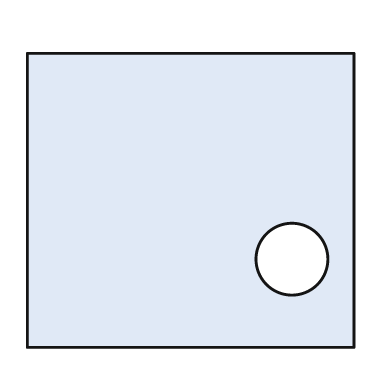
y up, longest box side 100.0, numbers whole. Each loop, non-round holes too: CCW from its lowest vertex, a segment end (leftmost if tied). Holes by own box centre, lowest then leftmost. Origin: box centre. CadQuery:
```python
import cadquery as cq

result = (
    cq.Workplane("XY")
    .moveTo(-50.0, -45.0)
    .lineTo(50.0, -45.0)
    .lineTo(50.0, 45.0)
    .lineTo(-50.0, 45.0)
    .close()
    .moveTo(31.0, -18.0)
    .circle(11.0)
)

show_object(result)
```